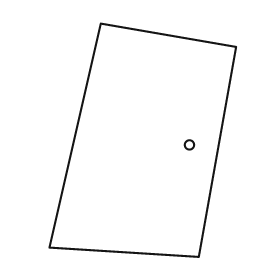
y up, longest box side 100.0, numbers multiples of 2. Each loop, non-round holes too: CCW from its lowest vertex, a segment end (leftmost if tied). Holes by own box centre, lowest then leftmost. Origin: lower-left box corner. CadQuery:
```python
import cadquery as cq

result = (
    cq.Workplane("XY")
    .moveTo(64.0, 0.0)
    .lineTo(80.0, 90.0)
    .lineTo(22.0, 100.0)
    .lineTo(0.0, 4.0)
    .close()
    .moveTo(60.0, 48.0)
    .circle(2.0)
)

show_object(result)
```